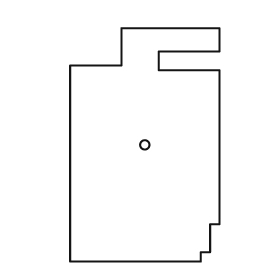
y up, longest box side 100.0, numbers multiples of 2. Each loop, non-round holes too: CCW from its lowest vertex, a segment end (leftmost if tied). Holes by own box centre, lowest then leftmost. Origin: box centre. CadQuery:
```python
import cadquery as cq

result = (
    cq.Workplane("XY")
    .moveTo(-32.0, -50.0)
    .lineTo(24.0, -50.0)
    .lineTo(24.0, -46.0)
    .lineTo(28.0, -46.0)
    .lineTo(28.0, -34.0)
    .lineTo(32.0, -34.0)
    .lineTo(32.0, 32.0)
    .lineTo(6.0, 32.0)
    .lineTo(6.0, 40.0)
    .lineTo(32.0, 40.0)
    .lineTo(32.0, 50.0)
    .lineTo(-10.0, 50.0)
    .lineTo(-10.0, 34.0)
    .lineTo(-32.0, 34.0)
    .close()
    .moveTo(0.0, 0.0)
    .circle(2.0)
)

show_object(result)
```